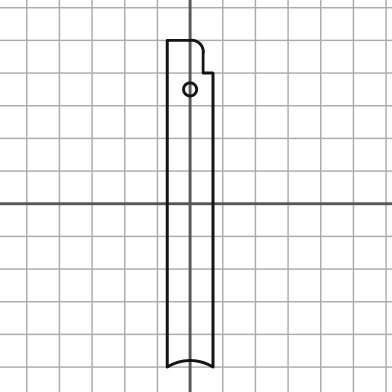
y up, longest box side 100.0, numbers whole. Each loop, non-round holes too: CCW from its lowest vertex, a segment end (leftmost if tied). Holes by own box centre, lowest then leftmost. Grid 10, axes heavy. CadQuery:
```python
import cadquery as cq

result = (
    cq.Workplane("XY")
    .moveTo(-7.0, -50.0)
    .threePointArc((0.0, -48.0), (7.0, -50.0))
    .lineTo(7.0, 40.0)
    .lineTo(4.0, 40.0)
    .lineTo(4.0, 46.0)
    .threePointArc((3.0, 49.0), (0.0, 50.0))
    .lineTo(-7.0, 50.0)
    .close()
    .moveTo(0.0, 35.0)
    .circle(2.0)
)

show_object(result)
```